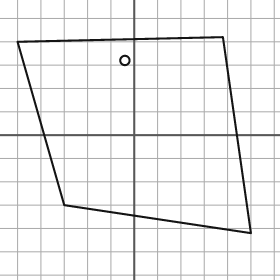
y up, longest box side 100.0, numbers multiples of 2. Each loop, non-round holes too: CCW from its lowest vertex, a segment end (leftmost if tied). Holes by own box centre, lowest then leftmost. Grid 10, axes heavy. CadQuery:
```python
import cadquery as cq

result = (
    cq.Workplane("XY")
    .moveTo(50.0, -42.0)
    .lineTo(38.0, 42.0)
    .lineTo(-50.0, 40.0)
    .lineTo(-30.0, -30.0)
    .close()
    .moveTo(-4.0, 32.0)
    .circle(2.0)
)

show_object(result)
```